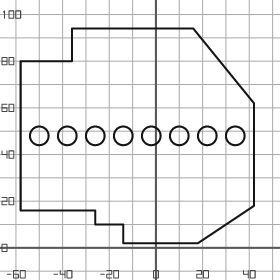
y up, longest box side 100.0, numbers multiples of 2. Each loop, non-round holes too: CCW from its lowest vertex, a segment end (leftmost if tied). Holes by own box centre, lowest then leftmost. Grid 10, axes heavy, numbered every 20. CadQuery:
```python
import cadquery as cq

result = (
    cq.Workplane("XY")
    .moveTo(-14.0, 2.0)
    .lineTo(18.0, 2.0)
    .lineTo(42.0, 18.0)
    .lineTo(42.0, 62.0)
    .lineTo(16.0, 94.0)
    .lineTo(-36.0, 94.0)
    .lineTo(-36.0, 80.0)
    .lineTo(-58.0, 80.0)
    .lineTo(-58.0, 16.0)
    .lineTo(-26.0, 16.0)
    .lineTo(-26.0, 10.0)
    .lineTo(-14.0, 10.0)
    .close()
    .moveTo(-50.0, 48.0)
    .circle(4.0)
    .moveTo(-38.0, 48.0)
    .circle(4.0)
    .moveTo(-26.0, 48.0)
    .circle(4.0)
    .moveTo(-14.0, 48.0)
    .circle(4.0)
    .moveTo(-2.0, 48.0)
    .circle(4.0)
    .moveTo(10.0, 48.0)
    .circle(4.0)
    .moveTo(22.0, 48.0)
    .circle(4.0)
    .moveTo(34.0, 48.0)
    .circle(4.0)
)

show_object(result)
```